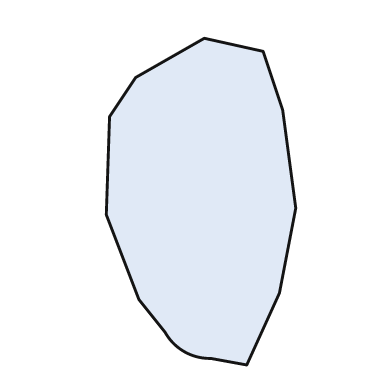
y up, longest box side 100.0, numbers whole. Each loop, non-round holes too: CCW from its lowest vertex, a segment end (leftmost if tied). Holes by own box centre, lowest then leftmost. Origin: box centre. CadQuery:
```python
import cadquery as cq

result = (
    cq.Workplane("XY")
    .moveTo(14.0, -50.0)
    .lineTo(24.0, -28.0)
    .lineTo(29.0, -2.0)
    .lineTo(25.0, 28.0)
    .lineTo(19.0, 46.0)
    .lineTo(1.0, 50.0)
    .lineTo(-20.0, 38.0)
    .lineTo(-28.0, 26.0)
    .lineTo(-29.0, -4.0)
    .lineTo(-19.0, -30.0)
    .lineTo(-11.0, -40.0)
    .threePointArc((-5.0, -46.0), (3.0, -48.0))
    .close()
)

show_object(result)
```